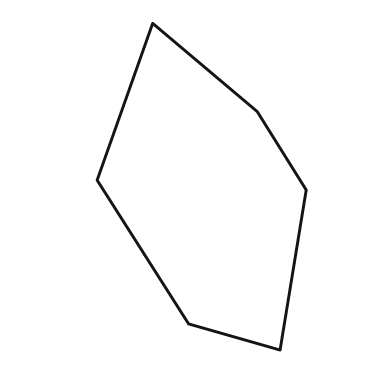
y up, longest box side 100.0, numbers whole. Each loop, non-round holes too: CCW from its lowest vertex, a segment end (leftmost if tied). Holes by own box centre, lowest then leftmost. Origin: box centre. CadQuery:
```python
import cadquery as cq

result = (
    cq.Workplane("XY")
    .moveTo(24.0, -50.0)
    .lineTo(32.0, -1.0)
    .lineTo(17.0, 23.0)
    .lineTo(-15.0, 50.0)
    .lineTo(-32.0, 2.0)
    .lineTo(-4.0, -42.0)
    .close()
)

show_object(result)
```